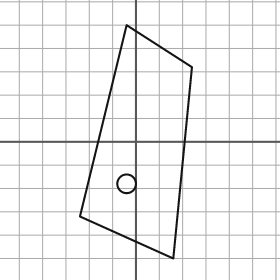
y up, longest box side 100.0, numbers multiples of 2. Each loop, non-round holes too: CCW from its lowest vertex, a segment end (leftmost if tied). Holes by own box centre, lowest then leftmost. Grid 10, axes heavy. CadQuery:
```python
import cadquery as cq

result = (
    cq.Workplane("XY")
    .moveTo(16.0, -50.0)
    .lineTo(24.0, 32.0)
    .lineTo(-4.0, 50.0)
    .lineTo(-24.0, -32.0)
    .close()
    .moveTo(-4.0, -18.0)
    .circle(4.0)
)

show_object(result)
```